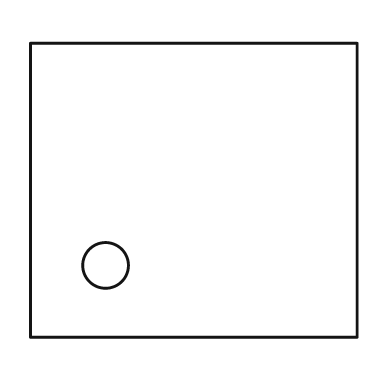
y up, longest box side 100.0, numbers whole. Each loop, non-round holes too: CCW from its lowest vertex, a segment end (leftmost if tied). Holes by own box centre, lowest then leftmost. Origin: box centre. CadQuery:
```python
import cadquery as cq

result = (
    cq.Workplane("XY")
    .moveTo(-50.0, -45.0)
    .lineTo(50.0, -45.0)
    .lineTo(50.0, 45.0)
    .lineTo(-50.0, 45.0)
    .close()
    .moveTo(-27.0, -23.0)
    .circle(7.0)
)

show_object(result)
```